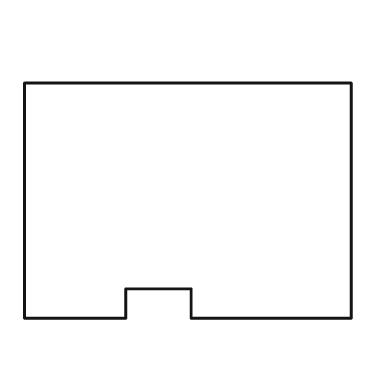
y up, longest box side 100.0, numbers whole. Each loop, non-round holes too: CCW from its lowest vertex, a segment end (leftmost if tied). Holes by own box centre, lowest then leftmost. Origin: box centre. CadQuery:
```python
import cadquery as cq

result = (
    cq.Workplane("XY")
    .moveTo(-50.0, -36.0)
    .lineTo(-19.0, -36.0)
    .lineTo(-19.0, -27.0)
    .lineTo(1.0, -27.0)
    .lineTo(1.0, -36.0)
    .lineTo(50.0, -36.0)
    .lineTo(50.0, 36.0)
    .lineTo(-50.0, 36.0)
    .close()
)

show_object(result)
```